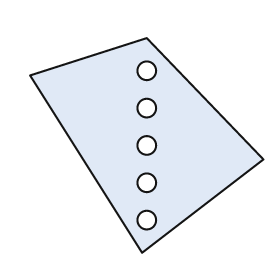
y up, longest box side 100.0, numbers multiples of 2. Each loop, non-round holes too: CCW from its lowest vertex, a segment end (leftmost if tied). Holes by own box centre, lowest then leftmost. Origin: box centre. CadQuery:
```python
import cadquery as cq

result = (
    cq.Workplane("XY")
    .moveTo(-2.0, -46.0)
    .lineTo(50.0, -6.0)
    .lineTo(0.0, 46.0)
    .lineTo(-50.0, 30.0)
    .close()
    .moveTo(0.0, -32.0)
    .circle(4.0)
    .moveTo(0.0, -16.0)
    .circle(4.0)
    .moveTo(0.0, 0.0)
    .circle(4.0)
    .moveTo(0.0, 16.0)
    .circle(4.0)
    .moveTo(0.0, 32.0)
    .circle(4.0)
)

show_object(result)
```